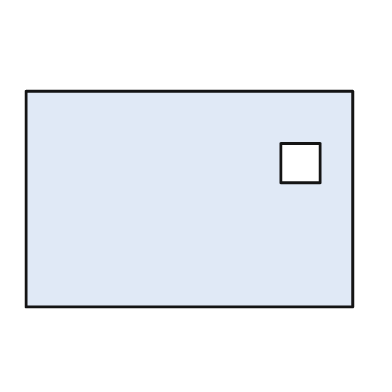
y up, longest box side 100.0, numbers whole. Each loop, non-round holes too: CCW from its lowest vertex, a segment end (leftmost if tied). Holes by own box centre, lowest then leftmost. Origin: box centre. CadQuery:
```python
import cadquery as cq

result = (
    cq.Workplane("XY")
    .moveTo(-50.0, -33.0)
    .lineTo(50.0, -33.0)
    .lineTo(50.0, 33.0)
    .lineTo(-50.0, 33.0)
    .close()
    .moveTo(28.0, 5.0)
    .lineTo(40.0, 5.0)
    .lineTo(40.0, 17.0)
    .lineTo(28.0, 17.0)
    .close()
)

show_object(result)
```